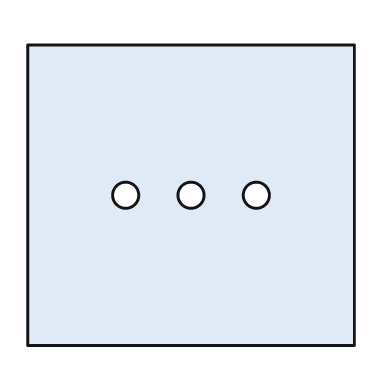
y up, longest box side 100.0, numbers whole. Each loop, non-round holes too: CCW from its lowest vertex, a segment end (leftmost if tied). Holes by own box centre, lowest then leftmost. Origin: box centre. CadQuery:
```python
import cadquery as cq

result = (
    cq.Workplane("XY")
    .moveTo(-50.0, -46.0)
    .lineTo(50.0, -46.0)
    .lineTo(50.0, 46.0)
    .lineTo(-50.0, 46.0)
    .close()
    .moveTo(-20.0, 0.0)
    .circle(4.0)
    .moveTo(0.0, 0.0)
    .circle(4.0)
    .moveTo(20.0, 0.0)
    .circle(4.0)
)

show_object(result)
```